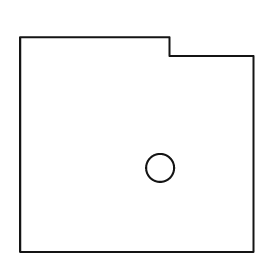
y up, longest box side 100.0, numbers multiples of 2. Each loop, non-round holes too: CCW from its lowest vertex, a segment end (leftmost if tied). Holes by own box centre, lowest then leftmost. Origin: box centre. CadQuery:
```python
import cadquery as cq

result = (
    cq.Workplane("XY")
    .moveTo(-50.0, -46.0)
    .lineTo(50.0, -46.0)
    .lineTo(50.0, 38.0)
    .lineTo(14.0, 38.0)
    .lineTo(14.0, 46.0)
    .lineTo(-50.0, 46.0)
    .close()
    .moveTo(10.0, -10.0)
    .circle(6.0)
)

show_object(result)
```